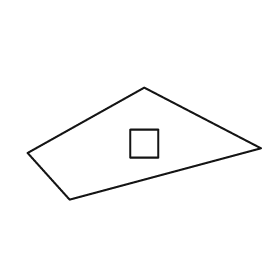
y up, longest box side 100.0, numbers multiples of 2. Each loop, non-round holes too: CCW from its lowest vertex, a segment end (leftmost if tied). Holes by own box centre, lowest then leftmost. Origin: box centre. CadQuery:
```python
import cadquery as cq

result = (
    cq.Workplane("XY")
    .moveTo(-32.0, -24.0)
    .lineTo(50.0, -2.0)
    .lineTo(0.0, 24.0)
    .lineTo(-50.0, -4.0)
    .close()
    .moveTo(-6.0, -6.0)
    .lineTo(6.0, -6.0)
    .lineTo(6.0, 6.0)
    .lineTo(-6.0, 6.0)
    .close()
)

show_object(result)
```